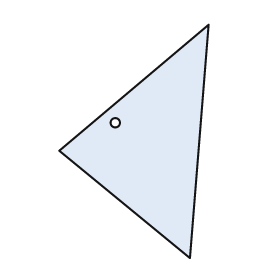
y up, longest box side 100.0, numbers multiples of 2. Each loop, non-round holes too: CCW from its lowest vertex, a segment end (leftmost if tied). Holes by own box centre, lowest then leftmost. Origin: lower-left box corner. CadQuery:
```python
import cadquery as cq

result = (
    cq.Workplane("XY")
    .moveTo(56.0, 0.0)
    .lineTo(64.0, 100.0)
    .lineTo(0.0, 46.0)
    .close()
    .moveTo(24.0, 58.0)
    .circle(2.0)
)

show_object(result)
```